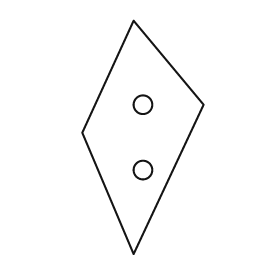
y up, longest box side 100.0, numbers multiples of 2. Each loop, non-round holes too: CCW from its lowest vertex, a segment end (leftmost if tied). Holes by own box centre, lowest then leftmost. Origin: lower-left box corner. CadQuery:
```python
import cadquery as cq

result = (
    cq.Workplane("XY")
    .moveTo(22.0, 0.0)
    .lineTo(52.0, 64.0)
    .lineTo(22.0, 100.0)
    .lineTo(0.0, 52.0)
    .close()
    .moveTo(26.0, 36.0)
    .circle(4.0)
    .moveTo(26.0, 64.0)
    .circle(4.0)
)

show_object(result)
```